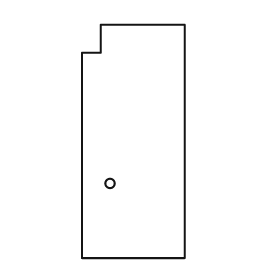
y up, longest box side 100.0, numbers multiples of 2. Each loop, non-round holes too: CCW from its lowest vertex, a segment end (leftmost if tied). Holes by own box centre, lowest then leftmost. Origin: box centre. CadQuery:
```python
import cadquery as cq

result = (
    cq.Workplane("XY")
    .moveTo(-22.0, -50.0)
    .lineTo(22.0, -50.0)
    .lineTo(22.0, 50.0)
    .lineTo(-14.0, 50.0)
    .lineTo(-14.0, 38.0)
    .lineTo(-22.0, 38.0)
    .close()
    .moveTo(-10.0, -18.0)
    .circle(2.0)
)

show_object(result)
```